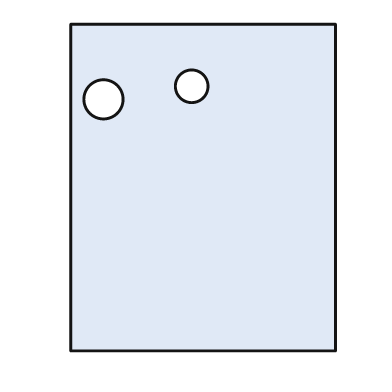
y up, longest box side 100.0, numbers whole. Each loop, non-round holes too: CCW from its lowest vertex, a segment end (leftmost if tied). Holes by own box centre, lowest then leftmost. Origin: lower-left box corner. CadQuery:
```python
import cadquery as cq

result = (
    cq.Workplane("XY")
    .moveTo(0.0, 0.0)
    .lineTo(81.0, 0.0)
    .lineTo(81.0, 100.0)
    .lineTo(0.0, 100.0)
    .close()
    .moveTo(10.0, 77.0)
    .circle(6.0)
    .moveTo(37.0, 81.0)
    .circle(5.0)
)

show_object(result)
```